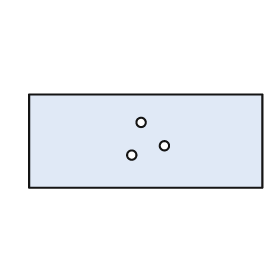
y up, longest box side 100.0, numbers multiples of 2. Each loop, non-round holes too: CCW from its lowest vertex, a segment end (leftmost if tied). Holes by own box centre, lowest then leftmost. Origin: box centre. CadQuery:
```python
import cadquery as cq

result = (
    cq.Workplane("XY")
    .moveTo(-50.0, -20.0)
    .lineTo(50.0, -20.0)
    .lineTo(50.0, 20.0)
    .lineTo(-50.0, 20.0)
    .close()
    .moveTo(-6.0, -6.0)
    .circle(2.0)
    .moveTo(8.0, -2.0)
    .circle(2.0)
    .moveTo(-2.0, 8.0)
    .circle(2.0)
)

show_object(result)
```